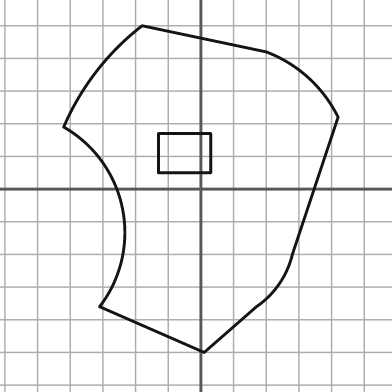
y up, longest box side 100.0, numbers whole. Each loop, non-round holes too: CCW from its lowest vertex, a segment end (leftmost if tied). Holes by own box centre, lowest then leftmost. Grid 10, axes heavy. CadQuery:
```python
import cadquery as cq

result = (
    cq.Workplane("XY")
    .moveTo(1.0, -50.0)
    .lineTo(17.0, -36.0)
    .threePointArc((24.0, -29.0), (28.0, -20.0))
    .lineTo(42.0, 22.0)
    .threePointArc((33.0, 34.0), (20.0, 42.0))
    .lineTo(-18.0, 50.0)
    .threePointArc((-32.0, 36.0), (-42.0, 19.0))
    .threePointArc((-24.0, -6.0), (-31.0, -36.0))
    .close()
    .moveTo(-13.0, 5.0)
    .lineTo(3.0, 5.0)
    .lineTo(3.0, 17.0)
    .lineTo(-13.0, 17.0)
    .close()
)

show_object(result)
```